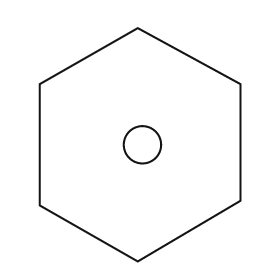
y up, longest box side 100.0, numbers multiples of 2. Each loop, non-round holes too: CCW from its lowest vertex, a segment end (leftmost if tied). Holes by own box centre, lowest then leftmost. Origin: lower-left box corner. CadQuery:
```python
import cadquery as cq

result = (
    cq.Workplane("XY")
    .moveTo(42.0, 0.0)
    .lineTo(86.0, 26.0)
    .lineTo(86.0, 76.0)
    .lineTo(42.0, 100.0)
    .lineTo(0.0, 76.0)
    .lineTo(0.0, 24.0)
    .close()
    .moveTo(44.0, 50.0)
    .circle(8.0)
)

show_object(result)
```